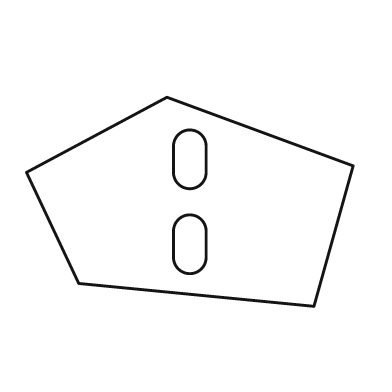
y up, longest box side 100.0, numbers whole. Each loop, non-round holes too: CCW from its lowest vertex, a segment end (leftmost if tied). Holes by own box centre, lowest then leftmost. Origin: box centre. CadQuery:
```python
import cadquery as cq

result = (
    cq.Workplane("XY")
    .moveTo(38.0, -32.0)
    .lineTo(50.0, 11.0)
    .lineTo(-7.0, 32.0)
    .lineTo(-50.0, 9.0)
    .lineTo(-34.0, -25.0)
    .close()
    .moveTo(-5.0, -17.0)
    .threePointArc((0.0, -22.0), (5.0, -17.0))
    .lineTo(5.0, -9.0)
    .threePointArc((0.0, -4.0), (-5.0, -9.0))
    .close()
    .moveTo(-5.0, 9.0)
    .threePointArc((0.0, 4.0), (5.0, 9.0))
    .lineTo(5.0, 17.0)
    .threePointArc((0.0, 22.0), (-5.0, 17.0))
    .close()
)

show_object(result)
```